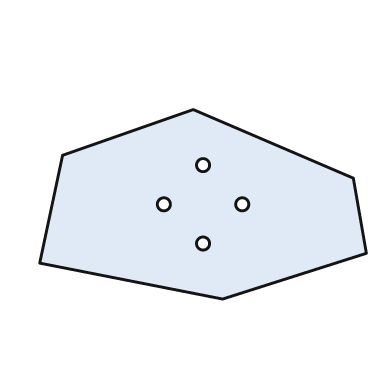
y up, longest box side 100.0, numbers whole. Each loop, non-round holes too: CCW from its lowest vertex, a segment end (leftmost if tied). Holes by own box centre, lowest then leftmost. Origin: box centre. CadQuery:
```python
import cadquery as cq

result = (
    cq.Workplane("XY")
    .moveTo(6.0, -29.0)
    .lineTo(50.0, -15.0)
    .lineTo(46.0, 8.0)
    .lineTo(-3.0, 29.0)
    .lineTo(-43.0, 15.0)
    .lineTo(-50.0, -18.0)
    .close()
    .moveTo(0.0, -12.0)
    .circle(2.0)
    .moveTo(-12.0, 0.0)
    .circle(2.0)
    .moveTo(12.0, 0.0)
    .circle(2.0)
    .moveTo(0.0, 12.0)
    .circle(2.0)
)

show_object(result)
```